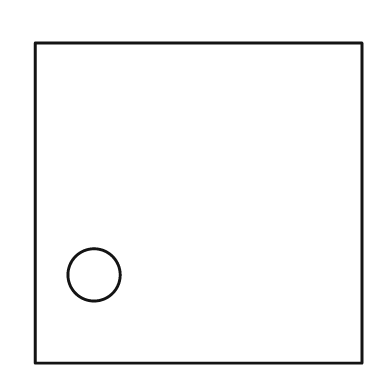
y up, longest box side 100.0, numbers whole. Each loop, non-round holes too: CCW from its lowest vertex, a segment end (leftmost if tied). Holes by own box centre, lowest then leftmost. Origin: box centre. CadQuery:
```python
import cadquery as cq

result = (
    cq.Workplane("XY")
    .moveTo(-50.0, -49.0)
    .lineTo(50.0, -49.0)
    .lineTo(50.0, 49.0)
    .lineTo(-50.0, 49.0)
    .close()
    .moveTo(-32.0, -22.0)
    .circle(8.0)
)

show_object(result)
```